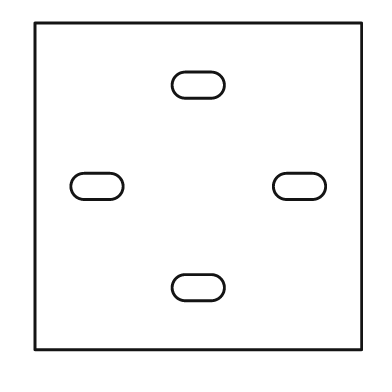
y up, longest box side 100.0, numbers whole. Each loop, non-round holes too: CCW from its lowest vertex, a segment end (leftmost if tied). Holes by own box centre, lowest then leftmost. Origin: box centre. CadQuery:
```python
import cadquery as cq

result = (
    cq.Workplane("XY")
    .moveTo(-50.0, -50.0)
    .lineTo(50.0, -50.0)
    .lineTo(50.0, 50.0)
    .lineTo(-50.0, 50.0)
    .close()
    .moveTo(-4.0, -35.0)
    .lineTo(4.0, -35.0)
    .threePointArc((8.0, -31.0), (4.0, -27.0))
    .lineTo(-4.0, -27.0)
    .threePointArc((-8.0, -31.0), (-4.0, -35.0))
    .close()
    .moveTo(-35.0, -4.0)
    .lineTo(-27.0, -4.0)
    .threePointArc((-23.0, 0.0), (-27.0, 4.0))
    .lineTo(-35.0, 4.0)
    .threePointArc((-39.0, 0.0), (-35.0, -4.0))
    .close()
    .moveTo(27.0, -4.0)
    .lineTo(35.0, -4.0)
    .threePointArc((39.0, 0.0), (35.0, 4.0))
    .lineTo(27.0, 4.0)
    .threePointArc((23.0, 0.0), (27.0, -4.0))
    .close()
    .moveTo(-4.0, 27.0)
    .lineTo(4.0, 27.0)
    .threePointArc((8.0, 31.0), (4.0, 35.0))
    .lineTo(-4.0, 35.0)
    .threePointArc((-8.0, 31.0), (-4.0, 27.0))
    .close()
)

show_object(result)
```